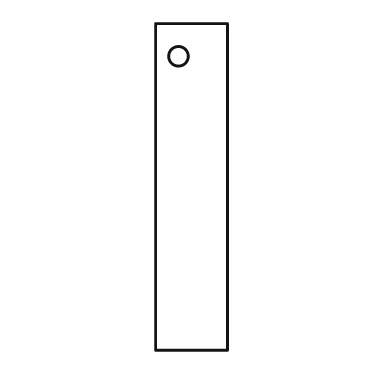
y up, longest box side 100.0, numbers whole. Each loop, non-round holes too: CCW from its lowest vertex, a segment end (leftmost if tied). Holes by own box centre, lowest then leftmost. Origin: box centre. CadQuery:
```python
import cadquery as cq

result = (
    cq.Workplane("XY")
    .moveTo(-11.0, -50.0)
    .lineTo(11.0, -50.0)
    .lineTo(11.0, 50.0)
    .lineTo(-11.0, 50.0)
    .close()
    .moveTo(-4.0, 40.0)
    .circle(3.0)
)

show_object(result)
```